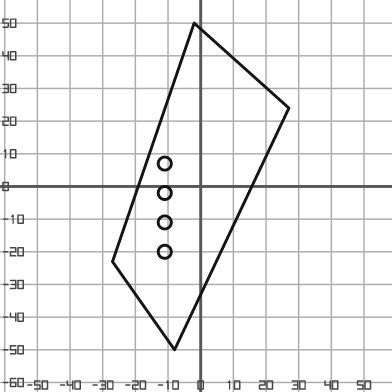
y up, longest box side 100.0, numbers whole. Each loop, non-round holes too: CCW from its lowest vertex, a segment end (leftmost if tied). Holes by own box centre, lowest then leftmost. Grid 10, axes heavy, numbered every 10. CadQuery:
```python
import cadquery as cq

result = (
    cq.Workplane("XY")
    .moveTo(-8.0, -50.0)
    .lineTo(27.0, 24.0)
    .lineTo(-2.0, 50.0)
    .lineTo(-27.0, -23.0)
    .close()
    .moveTo(-11.0, -20.0)
    .circle(2.0)
    .moveTo(-11.0, -11.0)
    .circle(2.0)
    .moveTo(-11.0, -2.0)
    .circle(2.0)
    .moveTo(-11.0, 7.0)
    .circle(2.0)
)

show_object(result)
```